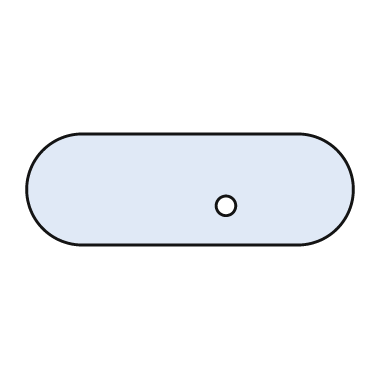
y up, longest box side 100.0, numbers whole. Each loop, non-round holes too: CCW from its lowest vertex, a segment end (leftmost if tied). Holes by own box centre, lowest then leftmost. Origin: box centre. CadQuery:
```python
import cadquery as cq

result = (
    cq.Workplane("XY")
    .moveTo(-33.0, -17.0)
    .lineTo(33.0, -17.0)
    .threePointArc((50.0, 0.0), (33.0, 17.0))
    .lineTo(-33.0, 17.0)
    .threePointArc((-50.0, 0.0), (-33.0, -17.0))
    .close()
    .moveTo(11.0, -5.0)
    .circle(3.0)
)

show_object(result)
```